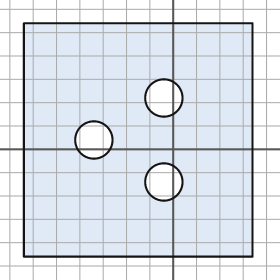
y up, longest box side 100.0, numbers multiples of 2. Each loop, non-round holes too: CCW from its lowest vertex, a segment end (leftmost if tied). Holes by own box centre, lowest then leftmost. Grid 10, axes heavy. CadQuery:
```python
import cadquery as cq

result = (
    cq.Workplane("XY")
    .moveTo(-64.0, -46.0)
    .lineTo(34.0, -46.0)
    .lineTo(34.0, 54.0)
    .lineTo(-64.0, 54.0)
    .close()
    .moveTo(-4.0, -14.0)
    .circle(8.0)
    .moveTo(-34.0, 4.0)
    .circle(8.0)
    .moveTo(-4.0, 22.0)
    .circle(8.0)
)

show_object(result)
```